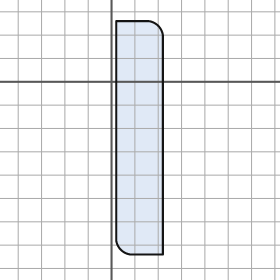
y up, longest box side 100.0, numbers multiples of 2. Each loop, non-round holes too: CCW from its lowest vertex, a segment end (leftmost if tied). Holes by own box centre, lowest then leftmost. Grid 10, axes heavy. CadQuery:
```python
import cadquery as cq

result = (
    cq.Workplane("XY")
    .moveTo(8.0, -74.0)
    .lineTo(22.0, -74.0)
    .lineTo(22.0, 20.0)
    .threePointArc((20.0, 24.0), (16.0, 26.0))
    .lineTo(2.0, 26.0)
    .lineTo(2.0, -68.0)
    .threePointArc((4.0, -72.0), (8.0, -74.0))
    .close()
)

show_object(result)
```